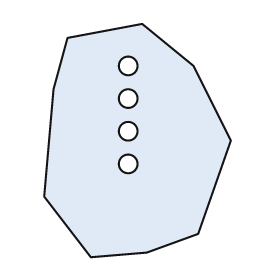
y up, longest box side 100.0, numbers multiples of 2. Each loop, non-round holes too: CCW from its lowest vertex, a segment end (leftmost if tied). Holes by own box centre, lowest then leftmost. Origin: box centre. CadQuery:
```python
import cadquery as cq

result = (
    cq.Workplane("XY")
    .moveTo(-20.0, -50.0)
    .lineTo(4.0, -48.0)
    .lineTo(26.0, -40.0)
    .lineTo(40.0, 0.0)
    .lineTo(24.0, 32.0)
    .lineTo(2.0, 50.0)
    .lineTo(-30.0, 44.0)
    .lineTo(-36.0, 22.0)
    .lineTo(-40.0, -24.0)
    .close()
    .moveTo(-4.0, -10.0)
    .circle(4.0)
    .moveTo(-4.0, 4.0)
    .circle(4.0)
    .moveTo(-4.0, 18.0)
    .circle(4.0)
    .moveTo(-4.0, 32.0)
    .circle(4.0)
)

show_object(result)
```